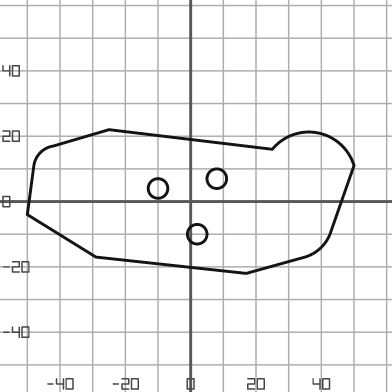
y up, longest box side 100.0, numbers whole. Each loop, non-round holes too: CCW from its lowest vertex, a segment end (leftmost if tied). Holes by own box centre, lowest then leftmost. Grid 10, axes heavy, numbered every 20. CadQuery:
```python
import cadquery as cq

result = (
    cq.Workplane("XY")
    .moveTo(17.0, -22.0)
    .lineTo(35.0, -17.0)
    .threePointArc((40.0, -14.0), (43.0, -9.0))
    .lineTo(50.0, 11.0)
    .threePointArc((39.0, 21.0), (25.0, 16.0))
    .lineTo(-25.0, 22.0)
    .lineTo(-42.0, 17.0)
    .threePointArc((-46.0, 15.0), (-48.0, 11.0))
    .lineTo(-50.0, -4.0)
    .lineTo(-29.0, -17.0)
    .close()
    .moveTo(2.0, -10.0)
    .circle(3.0)
    .moveTo(-10.0, 4.0)
    .circle(3.0)
    .moveTo(8.0, 7.0)
    .circle(3.0)
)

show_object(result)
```